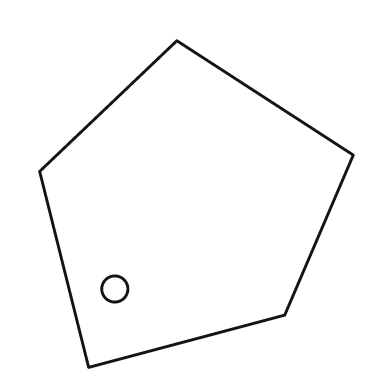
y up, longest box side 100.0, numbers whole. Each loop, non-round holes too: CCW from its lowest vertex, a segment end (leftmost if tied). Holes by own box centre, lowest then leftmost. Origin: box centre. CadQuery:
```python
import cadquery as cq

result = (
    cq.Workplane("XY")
    .moveTo(-33.0, -50.0)
    .lineTo(27.0, -34.0)
    .lineTo(48.0, 15.0)
    .lineTo(-6.0, 50.0)
    .lineTo(-48.0, 10.0)
    .close()
    .moveTo(-25.0, -26.0)
    .circle(4.0)
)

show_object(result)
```